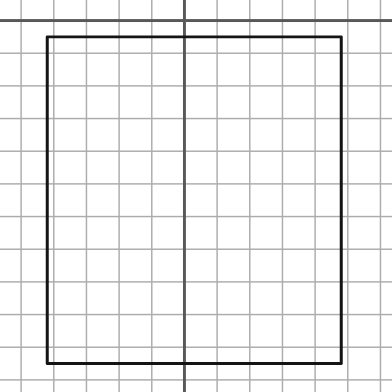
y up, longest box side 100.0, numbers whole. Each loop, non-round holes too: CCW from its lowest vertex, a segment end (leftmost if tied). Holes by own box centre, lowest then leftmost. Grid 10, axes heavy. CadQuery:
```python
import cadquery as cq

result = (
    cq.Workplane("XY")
    .moveTo(-42.0, -105.0)
    .lineTo(48.0, -105.0)
    .lineTo(48.0, -5.0)
    .lineTo(-42.0, -5.0)
    .close()
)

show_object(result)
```